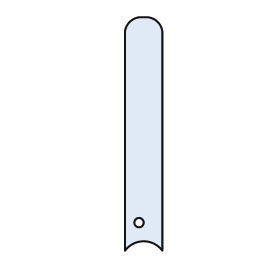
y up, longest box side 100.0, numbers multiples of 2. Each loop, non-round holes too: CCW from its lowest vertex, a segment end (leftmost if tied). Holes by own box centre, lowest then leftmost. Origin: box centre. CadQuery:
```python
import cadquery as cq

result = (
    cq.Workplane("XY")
    .moveTo(-8.0, -50.0)
    .threePointArc((0.0, -46.0), (8.0, -50.0))
    .lineTo(8.0, 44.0)
    .threePointArc((6.0, 48.0), (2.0, 50.0))
    .lineTo(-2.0, 50.0)
    .threePointArc((-6.0, 48.0), (-8.0, 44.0))
    .close()
    .moveTo(-2.0, -38.0)
    .circle(2.0)
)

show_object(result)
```